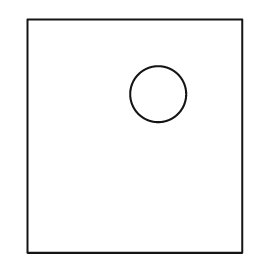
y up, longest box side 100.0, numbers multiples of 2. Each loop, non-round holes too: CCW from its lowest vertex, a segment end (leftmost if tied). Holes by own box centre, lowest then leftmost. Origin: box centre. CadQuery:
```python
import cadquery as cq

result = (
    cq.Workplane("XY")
    .moveTo(-46.0, -50.0)
    .lineTo(46.0, -50.0)
    .lineTo(46.0, 50.0)
    .lineTo(-46.0, 50.0)
    .close()
    .moveTo(10.0, 18.0)
    .circle(12.0)
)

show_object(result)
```